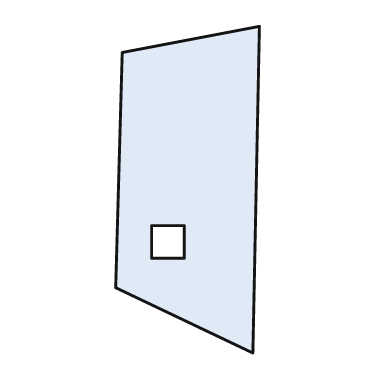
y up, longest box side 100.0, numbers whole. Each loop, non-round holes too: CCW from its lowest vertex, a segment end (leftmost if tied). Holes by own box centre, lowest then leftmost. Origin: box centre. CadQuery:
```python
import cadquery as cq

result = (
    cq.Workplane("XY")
    .moveTo(20.0, -50.0)
    .lineTo(22.0, 50.0)
    .lineTo(-20.0, 42.0)
    .lineTo(-22.0, -30.0)
    .close()
    .moveTo(-11.0, -21.0)
    .lineTo(-1.0, -21.0)
    .lineTo(-1.0, -11.0)
    .lineTo(-11.0, -11.0)
    .close()
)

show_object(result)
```